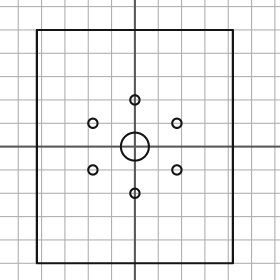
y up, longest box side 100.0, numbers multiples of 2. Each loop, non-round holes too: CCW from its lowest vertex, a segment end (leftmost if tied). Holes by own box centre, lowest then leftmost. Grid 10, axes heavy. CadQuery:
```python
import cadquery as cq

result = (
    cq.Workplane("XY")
    .moveTo(-42.0, -50.0)
    .lineTo(42.0, -50.0)
    .lineTo(42.0, 50.0)
    .lineTo(-42.0, 50.0)
    .close()
    .moveTo(0.0, -20.0)
    .circle(2.0)
    .moveTo(-18.0, -10.0)
    .circle(2.0)
    .moveTo(18.0, -10.0)
    .circle(2.0)
    .moveTo(0.0, 0.0)
    .circle(6.0)
    .moveTo(-18.0, 10.0)
    .circle(2.0)
    .moveTo(18.0, 10.0)
    .circle(2.0)
    .moveTo(0.0, 20.0)
    .circle(2.0)
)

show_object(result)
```